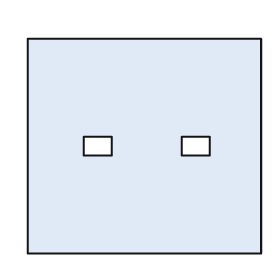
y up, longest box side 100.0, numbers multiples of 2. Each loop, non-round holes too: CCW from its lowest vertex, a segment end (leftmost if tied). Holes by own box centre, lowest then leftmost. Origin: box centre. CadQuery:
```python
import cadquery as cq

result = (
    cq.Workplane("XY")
    .moveTo(-50.0, -46.0)
    .lineTo(50.0, -46.0)
    .lineTo(50.0, 46.0)
    .lineTo(-50.0, 46.0)
    .close()
    .moveTo(-26.0, -4.0)
    .lineTo(-14.0, -4.0)
    .lineTo(-14.0, 4.0)
    .lineTo(-26.0, 4.0)
    .close()
    .moveTo(16.0, -4.0)
    .lineTo(28.0, -4.0)
    .lineTo(28.0, 4.0)
    .lineTo(16.0, 4.0)
    .close()
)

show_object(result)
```